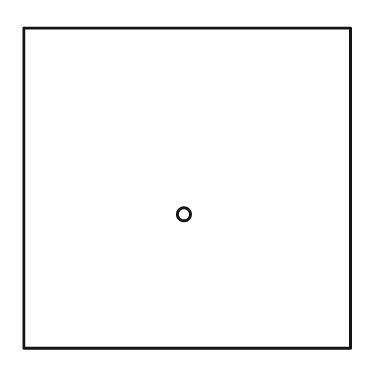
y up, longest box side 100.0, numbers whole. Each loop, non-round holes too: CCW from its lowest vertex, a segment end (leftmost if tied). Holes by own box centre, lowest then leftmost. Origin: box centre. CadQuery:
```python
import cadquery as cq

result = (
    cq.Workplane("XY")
    .moveTo(-50.0, -49.0)
    .lineTo(50.0, -49.0)
    .lineTo(50.0, 49.0)
    .lineTo(-50.0, 49.0)
    .close()
    .moveTo(-1.0, -8.0)
    .circle(2.0)
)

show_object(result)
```